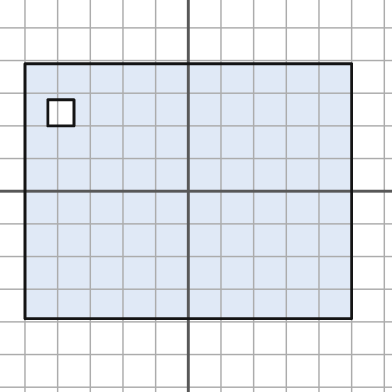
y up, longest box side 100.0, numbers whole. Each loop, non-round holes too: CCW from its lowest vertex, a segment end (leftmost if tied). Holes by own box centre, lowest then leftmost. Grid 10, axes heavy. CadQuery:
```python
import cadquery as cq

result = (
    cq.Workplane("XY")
    .moveTo(-50.0, -39.0)
    .lineTo(50.0, -39.0)
    .lineTo(50.0, 39.0)
    .lineTo(-50.0, 39.0)
    .close()
    .moveTo(-43.0, 20.0)
    .lineTo(-35.0, 20.0)
    .lineTo(-35.0, 28.0)
    .lineTo(-43.0, 28.0)
    .close()
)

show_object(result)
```